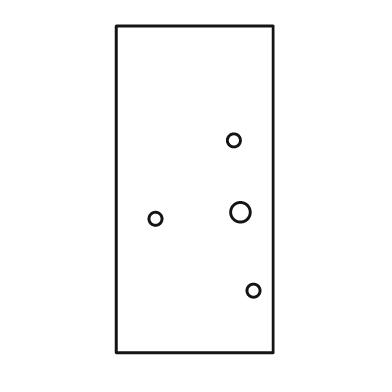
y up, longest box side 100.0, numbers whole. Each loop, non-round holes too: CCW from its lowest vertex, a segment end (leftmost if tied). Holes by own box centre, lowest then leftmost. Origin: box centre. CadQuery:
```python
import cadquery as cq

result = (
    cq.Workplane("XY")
    .moveTo(-24.0, -50.0)
    .lineTo(24.0, -50.0)
    .lineTo(24.0, 50.0)
    .lineTo(-24.0, 50.0)
    .close()
    .moveTo(18.0, -31.0)
    .circle(2.0)
    .moveTo(-12.0, -9.0)
    .circle(2.0)
    .moveTo(14.0, -7.0)
    .circle(3.0)
    .moveTo(12.0, 15.0)
    .circle(2.0)
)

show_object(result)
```